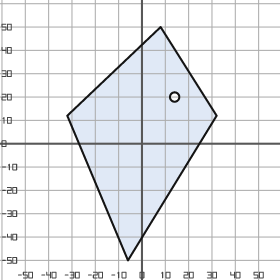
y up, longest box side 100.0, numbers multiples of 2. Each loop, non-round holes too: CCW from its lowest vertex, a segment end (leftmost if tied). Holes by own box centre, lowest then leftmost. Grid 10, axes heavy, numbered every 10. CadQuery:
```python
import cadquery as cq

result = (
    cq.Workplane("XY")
    .moveTo(-6.0, -50.0)
    .lineTo(32.0, 12.0)
    .lineTo(8.0, 50.0)
    .lineTo(-32.0, 12.0)
    .close()
    .moveTo(14.0, 20.0)
    .circle(2.0)
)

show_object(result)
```